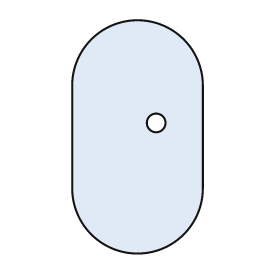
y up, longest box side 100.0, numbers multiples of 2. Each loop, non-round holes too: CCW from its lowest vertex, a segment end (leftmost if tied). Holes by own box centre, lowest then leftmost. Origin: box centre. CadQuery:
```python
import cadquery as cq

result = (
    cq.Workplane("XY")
    .moveTo(-28.0, -22.0)
    .threePointArc((0.0, -50.0), (28.0, -22.0))
    .lineTo(28.0, 22.0)
    .threePointArc((0.0, 50.0), (-28.0, 22.0))
    .close()
    .moveTo(8.0, 6.0)
    .circle(4.0)
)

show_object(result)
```